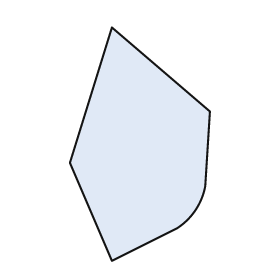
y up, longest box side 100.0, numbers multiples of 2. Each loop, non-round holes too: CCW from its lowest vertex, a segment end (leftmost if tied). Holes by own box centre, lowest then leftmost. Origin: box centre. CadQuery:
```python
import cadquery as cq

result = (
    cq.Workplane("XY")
    .moveTo(-12.0, -50.0)
    .lineTo(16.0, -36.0)
    .threePointArc((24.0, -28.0), (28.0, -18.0))
    .lineTo(30.0, 14.0)
    .lineTo(-12.0, 50.0)
    .lineTo(-30.0, -8.0)
    .close()
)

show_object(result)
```